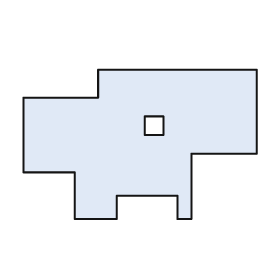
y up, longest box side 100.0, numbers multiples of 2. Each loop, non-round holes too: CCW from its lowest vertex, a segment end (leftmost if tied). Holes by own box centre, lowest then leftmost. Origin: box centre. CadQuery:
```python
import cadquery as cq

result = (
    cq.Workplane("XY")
    .moveTo(-28.0, -32.0)
    .lineTo(-10.0, -32.0)
    .lineTo(-10.0, -22.0)
    .lineTo(16.0, -22.0)
    .lineTo(16.0, -32.0)
    .lineTo(22.0, -32.0)
    .lineTo(22.0, -4.0)
    .lineTo(50.0, -4.0)
    .lineTo(50.0, 32.0)
    .lineTo(-18.0, 32.0)
    .lineTo(-18.0, 20.0)
    .lineTo(-50.0, 20.0)
    .lineTo(-50.0, -12.0)
    .lineTo(-28.0, -12.0)
    .close()
    .moveTo(2.0, 4.0)
    .lineTo(10.0, 4.0)
    .lineTo(10.0, 12.0)
    .lineTo(2.0, 12.0)
    .close()
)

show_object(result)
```